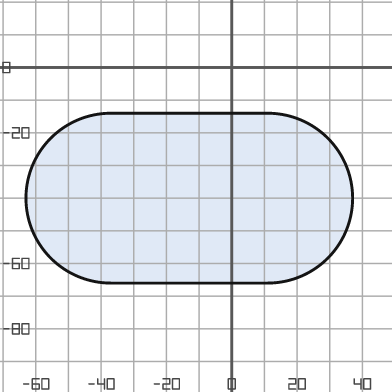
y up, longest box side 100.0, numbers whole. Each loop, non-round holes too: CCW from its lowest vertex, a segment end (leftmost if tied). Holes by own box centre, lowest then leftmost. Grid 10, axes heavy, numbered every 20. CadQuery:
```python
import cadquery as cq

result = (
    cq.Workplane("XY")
    .moveTo(-37.0, -66.0)
    .lineTo(11.0, -66.0)
    .threePointArc((37.0, -40.0), (11.0, -14.0))
    .lineTo(-37.0, -14.0)
    .threePointArc((-63.0, -40.0), (-37.0, -66.0))
    .close()
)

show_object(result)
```